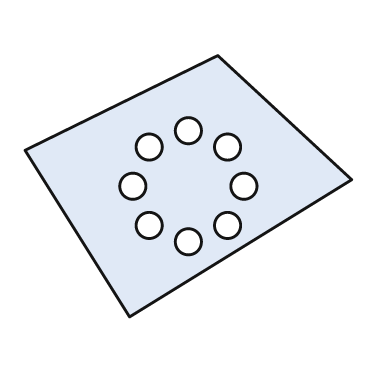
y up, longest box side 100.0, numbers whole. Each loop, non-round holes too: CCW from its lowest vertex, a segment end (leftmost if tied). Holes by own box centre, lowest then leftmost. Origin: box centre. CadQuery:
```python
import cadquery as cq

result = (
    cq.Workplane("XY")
    .moveTo(-18.0, -40.0)
    .lineTo(50.0, 2.0)
    .lineTo(9.0, 40.0)
    .lineTo(-50.0, 11.0)
    .close()
    .moveTo(0.0, -17.0)
    .circle(4.0)
    .moveTo(-12.0, -12.0)
    .circle(4.0)
    .moveTo(12.0, -12.0)
    .circle(4.0)
    .moveTo(-17.0, 0.0)
    .circle(4.0)
    .moveTo(17.0, 0.0)
    .circle(4.0)
    .moveTo(-12.0, 12.0)
    .circle(4.0)
    .moveTo(12.0, 12.0)
    .circle(4.0)
    .moveTo(0.0, 17.0)
    .circle(4.0)
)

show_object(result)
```